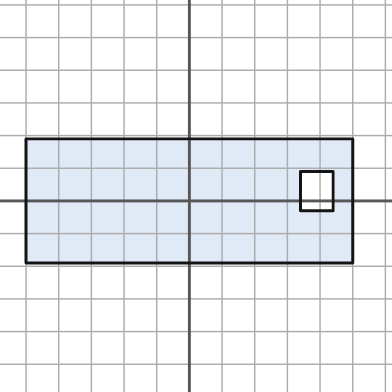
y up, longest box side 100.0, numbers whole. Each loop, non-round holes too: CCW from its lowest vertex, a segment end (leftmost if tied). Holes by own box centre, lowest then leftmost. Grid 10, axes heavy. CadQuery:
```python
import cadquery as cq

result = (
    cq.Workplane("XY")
    .moveTo(-50.0, -19.0)
    .lineTo(50.0, -19.0)
    .lineTo(50.0, 19.0)
    .lineTo(-50.0, 19.0)
    .close()
    .moveTo(34.0, -3.0)
    .lineTo(44.0, -3.0)
    .lineTo(44.0, 9.0)
    .lineTo(34.0, 9.0)
    .close()
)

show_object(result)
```